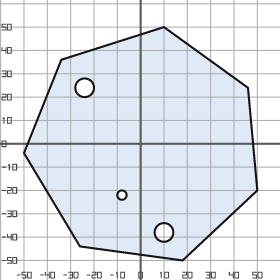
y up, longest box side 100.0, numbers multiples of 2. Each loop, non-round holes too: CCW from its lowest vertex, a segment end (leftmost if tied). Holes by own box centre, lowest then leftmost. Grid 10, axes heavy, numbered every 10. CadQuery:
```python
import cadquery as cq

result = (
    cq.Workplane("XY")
    .moveTo(18.0, -50.0)
    .lineTo(50.0, -20.0)
    .lineTo(46.0, 24.0)
    .lineTo(10.0, 50.0)
    .lineTo(-34.0, 36.0)
    .lineTo(-50.0, -4.0)
    .lineTo(-26.0, -44.0)
    .close()
    .moveTo(10.0, -38.0)
    .circle(4.0)
    .moveTo(-8.0, -22.0)
    .circle(2.0)
    .moveTo(-24.0, 24.0)
    .circle(4.0)
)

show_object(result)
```